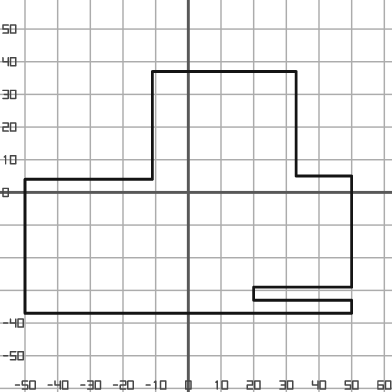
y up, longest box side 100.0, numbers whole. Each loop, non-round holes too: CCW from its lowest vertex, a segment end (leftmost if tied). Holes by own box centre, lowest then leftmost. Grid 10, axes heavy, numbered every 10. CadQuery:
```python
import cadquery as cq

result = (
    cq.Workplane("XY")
    .moveTo(-50.0, -37.0)
    .lineTo(50.0, -37.0)
    .lineTo(50.0, -33.0)
    .lineTo(20.0, -33.0)
    .lineTo(20.0, -29.0)
    .lineTo(50.0, -29.0)
    .lineTo(50.0, 5.0)
    .lineTo(33.0, 5.0)
    .lineTo(33.0, 37.0)
    .lineTo(-11.0, 37.0)
    .lineTo(-11.0, 4.0)
    .lineTo(-50.0, 4.0)
    .close()
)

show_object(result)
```